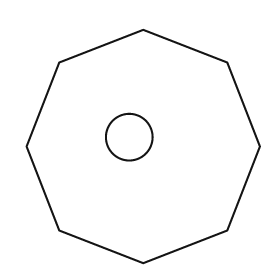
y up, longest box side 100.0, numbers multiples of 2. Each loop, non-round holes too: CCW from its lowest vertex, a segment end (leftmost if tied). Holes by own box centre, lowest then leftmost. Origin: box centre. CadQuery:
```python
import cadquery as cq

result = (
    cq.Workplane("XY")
    .moveTo(0.0, -50.0)
    .lineTo(36.0, -36.0)
    .lineTo(50.0, 0.0)
    .lineTo(36.0, 36.0)
    .lineTo(0.0, 50.0)
    .lineTo(-36.0, 36.0)
    .lineTo(-50.0, 0.0)
    .lineTo(-36.0, -36.0)
    .close()
    .moveTo(-6.0, 4.0)
    .circle(10.0)
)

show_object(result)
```